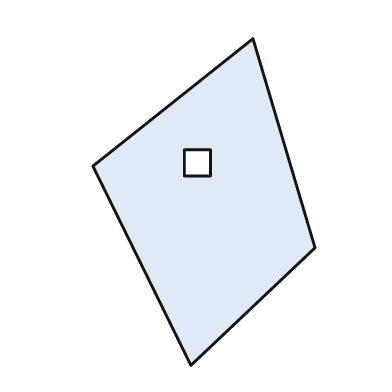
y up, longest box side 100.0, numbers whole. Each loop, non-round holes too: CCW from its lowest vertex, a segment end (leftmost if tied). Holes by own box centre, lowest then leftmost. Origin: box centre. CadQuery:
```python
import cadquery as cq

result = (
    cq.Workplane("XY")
    .moveTo(-4.0, -50.0)
    .lineTo(34.0, -14.0)
    .lineTo(15.0, 50.0)
    .lineTo(-34.0, 11.0)
    .close()
    .moveTo(-6.0, 8.0)
    .lineTo(2.0, 8.0)
    .lineTo(2.0, 16.0)
    .lineTo(-6.0, 16.0)
    .close()
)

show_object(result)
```